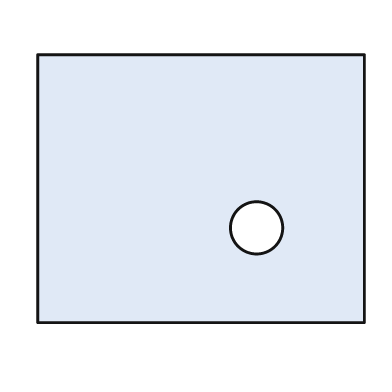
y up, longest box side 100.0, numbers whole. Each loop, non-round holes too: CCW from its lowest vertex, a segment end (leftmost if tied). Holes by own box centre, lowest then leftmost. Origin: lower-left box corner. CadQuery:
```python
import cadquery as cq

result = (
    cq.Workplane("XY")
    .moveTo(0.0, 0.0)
    .lineTo(100.0, 0.0)
    .lineTo(100.0, 82.0)
    .lineTo(0.0, 82.0)
    .close()
    .moveTo(67.0, 29.0)
    .circle(8.0)
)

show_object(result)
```